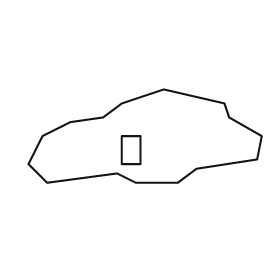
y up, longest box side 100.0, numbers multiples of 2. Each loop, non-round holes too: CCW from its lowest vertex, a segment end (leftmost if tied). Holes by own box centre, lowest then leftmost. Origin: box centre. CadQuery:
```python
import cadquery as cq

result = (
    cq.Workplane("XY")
    .moveTo(-42.0, -20.0)
    .lineTo(-12.0, -16.0)
    .lineTo(-4.0, -20.0)
    .lineTo(14.0, -20.0)
    .lineTo(22.0, -14.0)
    .lineTo(48.0, -10.0)
    .lineTo(50.0, 0.0)
    .lineTo(36.0, 8.0)
    .lineTo(34.0, 14.0)
    .lineTo(8.0, 20.0)
    .lineTo(-10.0, 14.0)
    .lineTo(-18.0, 8.0)
    .lineTo(-32.0, 6.0)
    .lineTo(-44.0, 0.0)
    .lineTo(-50.0, -12.0)
    .close()
    .moveTo(-10.0, -12.0)
    .lineTo(-2.0, -12.0)
    .lineTo(-2.0, 0.0)
    .lineTo(-10.0, 0.0)
    .close()
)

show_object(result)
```